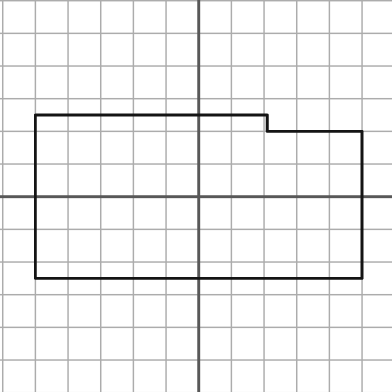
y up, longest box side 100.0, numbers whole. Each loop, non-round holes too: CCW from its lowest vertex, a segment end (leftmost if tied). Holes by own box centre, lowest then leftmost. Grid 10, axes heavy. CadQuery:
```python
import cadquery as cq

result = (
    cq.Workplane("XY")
    .moveTo(-50.0, -25.0)
    .lineTo(50.0, -25.0)
    .lineTo(50.0, 20.0)
    .lineTo(21.0, 20.0)
    .lineTo(21.0, 25.0)
    .lineTo(-50.0, 25.0)
    .close()
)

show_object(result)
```